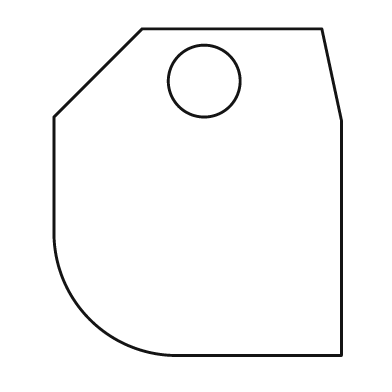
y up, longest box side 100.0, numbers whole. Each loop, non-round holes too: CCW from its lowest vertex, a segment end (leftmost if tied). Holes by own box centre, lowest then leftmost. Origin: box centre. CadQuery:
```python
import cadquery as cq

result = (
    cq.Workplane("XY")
    .moveTo(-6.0, -50.0)
    .lineTo(44.0, -50.0)
    .lineTo(44.0, 22.0)
    .lineTo(38.0, 50.0)
    .lineTo(-17.0, 50.0)
    .lineTo(-44.0, 23.0)
    .lineTo(-44.0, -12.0)
    .threePointArc((-33.0, -39.0), (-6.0, -50.0))
    .close()
    .moveTo(2.0, 34.0)
    .circle(11.0)
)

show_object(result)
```